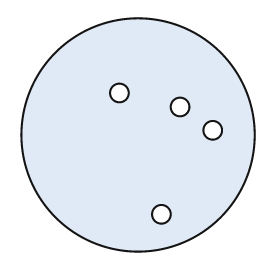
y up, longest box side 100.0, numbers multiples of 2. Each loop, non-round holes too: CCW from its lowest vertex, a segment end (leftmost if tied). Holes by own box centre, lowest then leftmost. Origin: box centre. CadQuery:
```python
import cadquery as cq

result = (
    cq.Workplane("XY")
    .moveTo(0.0, 0.0)
    .circle(50.0)
    .moveTo(10.0, -34.0)
    .circle(4.0)
    .moveTo(32.0, 2.0)
    .circle(4.0)
    .moveTo(18.0, 12.0)
    .circle(4.0)
    .moveTo(-8.0, 18.0)
    .circle(4.0)
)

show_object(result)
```